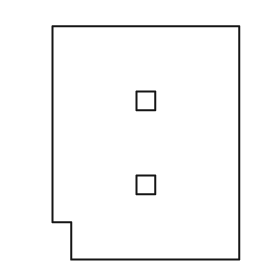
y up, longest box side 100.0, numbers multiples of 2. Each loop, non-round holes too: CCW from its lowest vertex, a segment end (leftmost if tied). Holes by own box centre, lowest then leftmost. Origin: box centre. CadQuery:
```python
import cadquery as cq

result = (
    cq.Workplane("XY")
    .moveTo(-32.0, -50.0)
    .lineTo(40.0, -50.0)
    .lineTo(40.0, 50.0)
    .lineTo(-40.0, 50.0)
    .lineTo(-40.0, -34.0)
    .lineTo(-32.0, -34.0)
    .close()
    .moveTo(-4.0, -22.0)
    .lineTo(4.0, -22.0)
    .lineTo(4.0, -14.0)
    .lineTo(-4.0, -14.0)
    .close()
    .moveTo(-4.0, 14.0)
    .lineTo(4.0, 14.0)
    .lineTo(4.0, 22.0)
    .lineTo(-4.0, 22.0)
    .close()
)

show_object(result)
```